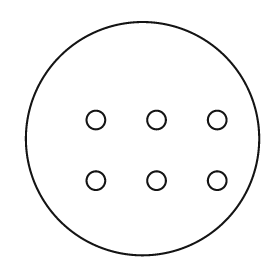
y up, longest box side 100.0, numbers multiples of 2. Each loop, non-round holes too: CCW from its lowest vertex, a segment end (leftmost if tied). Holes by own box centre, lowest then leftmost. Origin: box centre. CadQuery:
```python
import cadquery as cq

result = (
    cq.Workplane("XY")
    .moveTo(0.0, 0.0)
    .circle(50.0)
    .moveTo(-20.0, -18.0)
    .circle(4.0)
    .moveTo(6.0, -18.0)
    .circle(4.0)
    .moveTo(32.0, -18.0)
    .circle(4.0)
    .moveTo(-20.0, 8.0)
    .circle(4.0)
    .moveTo(6.0, 8.0)
    .circle(4.0)
    .moveTo(32.0, 8.0)
    .circle(4.0)
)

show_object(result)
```